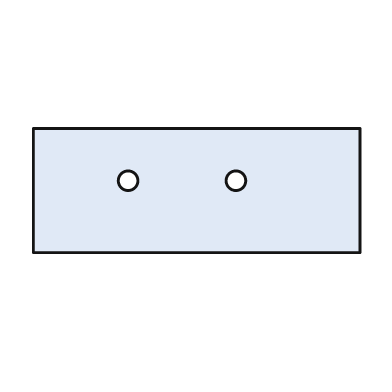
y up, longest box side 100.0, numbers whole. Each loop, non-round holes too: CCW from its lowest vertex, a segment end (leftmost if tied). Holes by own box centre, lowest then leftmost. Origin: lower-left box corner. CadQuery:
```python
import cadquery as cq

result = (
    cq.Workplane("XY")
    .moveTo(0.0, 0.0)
    .lineTo(100.0, 0.0)
    .lineTo(100.0, 38.0)
    .lineTo(0.0, 38.0)
    .close()
    .moveTo(29.0, 22.0)
    .circle(3.0)
    .moveTo(62.0, 22.0)
    .circle(3.0)
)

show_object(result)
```